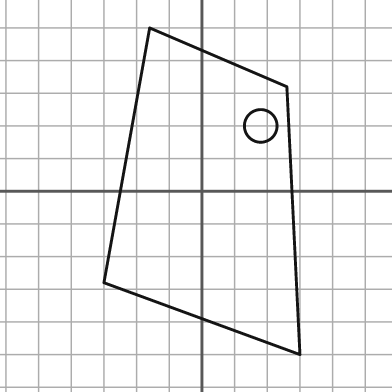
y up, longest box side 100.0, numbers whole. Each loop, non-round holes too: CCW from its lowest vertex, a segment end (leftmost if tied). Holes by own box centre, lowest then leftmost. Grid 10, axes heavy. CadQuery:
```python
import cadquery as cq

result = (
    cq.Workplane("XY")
    .moveTo(30.0, -50.0)
    .lineTo(26.0, 32.0)
    .lineTo(-16.0, 50.0)
    .lineTo(-30.0, -28.0)
    .close()
    .moveTo(18.0, 20.0)
    .circle(5.0)
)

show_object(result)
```